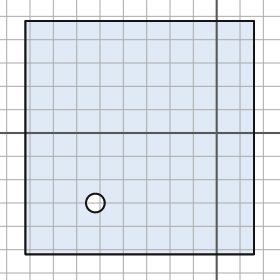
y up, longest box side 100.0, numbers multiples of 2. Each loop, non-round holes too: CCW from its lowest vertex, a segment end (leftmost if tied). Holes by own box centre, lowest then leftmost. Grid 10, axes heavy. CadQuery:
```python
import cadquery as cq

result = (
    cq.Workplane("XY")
    .moveTo(-82.0, -52.0)
    .lineTo(16.0, -52.0)
    .lineTo(16.0, 48.0)
    .lineTo(-82.0, 48.0)
    .close()
    .moveTo(-52.0, -30.0)
    .circle(4.0)
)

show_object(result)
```